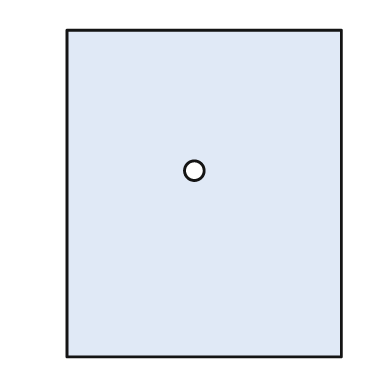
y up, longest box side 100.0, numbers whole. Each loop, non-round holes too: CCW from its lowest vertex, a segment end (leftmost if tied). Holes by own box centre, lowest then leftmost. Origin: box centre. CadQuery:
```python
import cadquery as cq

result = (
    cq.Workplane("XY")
    .moveTo(-42.0, -50.0)
    .lineTo(42.0, -50.0)
    .lineTo(42.0, 50.0)
    .lineTo(-42.0, 50.0)
    .close()
    .moveTo(-3.0, 7.0)
    .circle(3.0)
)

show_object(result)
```